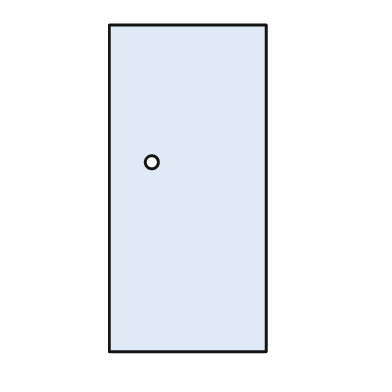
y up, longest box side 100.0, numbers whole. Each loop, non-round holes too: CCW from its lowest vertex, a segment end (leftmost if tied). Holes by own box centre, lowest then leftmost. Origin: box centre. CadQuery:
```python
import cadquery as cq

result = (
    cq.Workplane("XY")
    .moveTo(-24.0, -50.0)
    .lineTo(24.0, -50.0)
    .lineTo(24.0, 50.0)
    .lineTo(-24.0, 50.0)
    .close()
    .moveTo(-11.0, 8.0)
    .circle(2.0)
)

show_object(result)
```